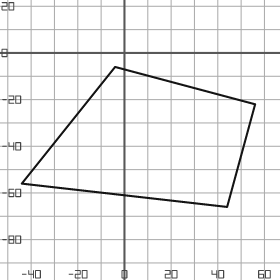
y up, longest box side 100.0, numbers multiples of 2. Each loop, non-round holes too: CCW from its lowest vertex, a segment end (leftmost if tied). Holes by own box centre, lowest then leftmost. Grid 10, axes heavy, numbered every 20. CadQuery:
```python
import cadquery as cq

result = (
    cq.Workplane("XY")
    .moveTo(44.0, -66.0)
    .lineTo(56.0, -22.0)
    .lineTo(-4.0, -6.0)
    .lineTo(-44.0, -56.0)
    .close()
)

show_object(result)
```